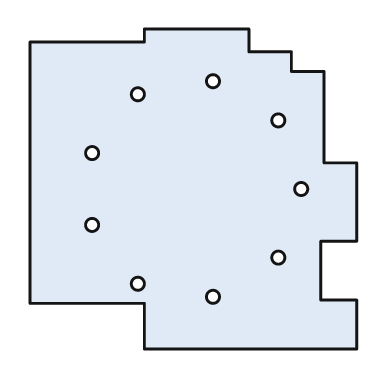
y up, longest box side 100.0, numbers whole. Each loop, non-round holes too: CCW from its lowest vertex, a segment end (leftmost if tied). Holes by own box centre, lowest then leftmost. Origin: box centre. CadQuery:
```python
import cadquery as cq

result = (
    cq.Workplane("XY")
    .moveTo(-15.0, -49.0)
    .lineTo(50.0, -49.0)
    .lineTo(50.0, -34.0)
    .lineTo(39.0, -34.0)
    .lineTo(39.0, -16.0)
    .lineTo(50.0, -16.0)
    .lineTo(50.0, 8.0)
    .lineTo(40.0, 8.0)
    .lineTo(40.0, 36.0)
    .lineTo(30.0, 36.0)
    .lineTo(30.0, 42.0)
    .lineTo(17.0, 42.0)
    .lineTo(17.0, 49.0)
    .lineTo(-15.0, 49.0)
    .lineTo(-15.0, 45.0)
    .lineTo(-50.0, 45.0)
    .lineTo(-50.0, -35.0)
    .lineTo(-15.0, -35.0)
    .close()
    .moveTo(6.0, -33.0)
    .circle(2.0)
    .moveTo(-17.0, -29.0)
    .circle(2.0)
    .moveTo(26.0, -21.0)
    .circle(2.0)
    .moveTo(-31.0, -11.0)
    .circle(2.0)
    .moveTo(33.0, 0.0)
    .circle(2.0)
    .moveTo(-31.0, 11.0)
    .circle(2.0)
    .moveTo(26.0, 21.0)
    .circle(2.0)
    .moveTo(-17.0, 29.0)
    .circle(2.0)
    .moveTo(6.0, 33.0)
    .circle(2.0)
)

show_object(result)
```